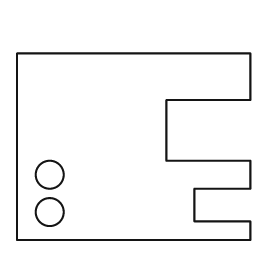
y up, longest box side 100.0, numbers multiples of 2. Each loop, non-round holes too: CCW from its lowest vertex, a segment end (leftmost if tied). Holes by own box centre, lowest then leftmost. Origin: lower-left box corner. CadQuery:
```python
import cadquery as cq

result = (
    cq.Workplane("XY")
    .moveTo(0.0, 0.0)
    .lineTo(100.0, 0.0)
    .lineTo(100.0, 8.0)
    .lineTo(76.0, 8.0)
    .lineTo(76.0, 22.0)
    .lineTo(100.0, 22.0)
    .lineTo(100.0, 34.0)
    .lineTo(64.0, 34.0)
    .lineTo(64.0, 60.0)
    .lineTo(100.0, 60.0)
    .lineTo(100.0, 80.0)
    .lineTo(0.0, 80.0)
    .close()
    .moveTo(14.0, 12.0)
    .circle(6.0)
    .moveTo(14.0, 28.0)
    .circle(6.0)
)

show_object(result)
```